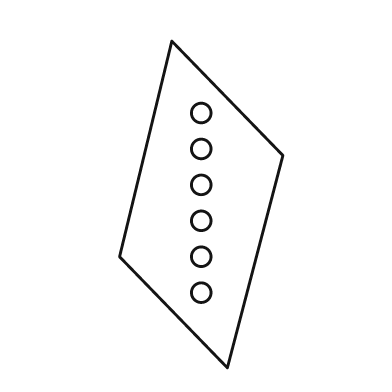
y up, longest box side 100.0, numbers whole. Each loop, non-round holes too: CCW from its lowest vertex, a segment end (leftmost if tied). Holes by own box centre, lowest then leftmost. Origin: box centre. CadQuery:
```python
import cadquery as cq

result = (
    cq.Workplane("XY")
    .moveTo(8.0, -50.0)
    .lineTo(25.0, 15.0)
    .lineTo(-9.0, 50.0)
    .lineTo(-25.0, -16.0)
    .close()
    .moveTo(0.0, -27.0)
    .circle(3.0)
    .moveTo(0.0, -16.0)
    .circle(3.0)
    .moveTo(0.0, -5.0)
    .circle(3.0)
    .moveTo(0.0, 6.0)
    .circle(3.0)
    .moveTo(0.0, 17.0)
    .circle(3.0)
    .moveTo(0.0, 28.0)
    .circle(3.0)
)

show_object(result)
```